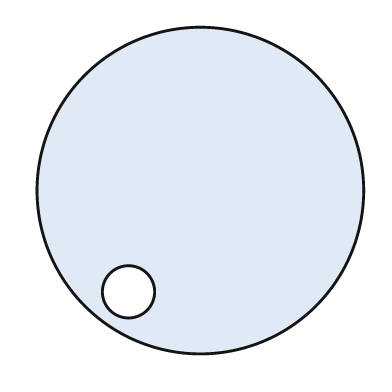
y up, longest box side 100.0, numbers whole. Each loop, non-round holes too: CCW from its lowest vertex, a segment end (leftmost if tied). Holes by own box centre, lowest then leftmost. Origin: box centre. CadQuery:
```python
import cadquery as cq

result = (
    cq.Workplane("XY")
    .moveTo(0.0, 0.0)
    .circle(50.0)
    .moveTo(-22.0, -31.0)
    .circle(8.0)
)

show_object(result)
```